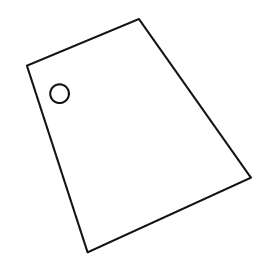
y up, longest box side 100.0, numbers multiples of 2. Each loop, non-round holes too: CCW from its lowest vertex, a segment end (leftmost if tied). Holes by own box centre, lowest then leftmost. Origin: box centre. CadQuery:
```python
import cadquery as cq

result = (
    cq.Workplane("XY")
    .moveTo(-22.0, -50.0)
    .lineTo(48.0, -18.0)
    .lineTo(0.0, 50.0)
    .lineTo(-48.0, 30.0)
    .close()
    .moveTo(-34.0, 18.0)
    .circle(4.0)
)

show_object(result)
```